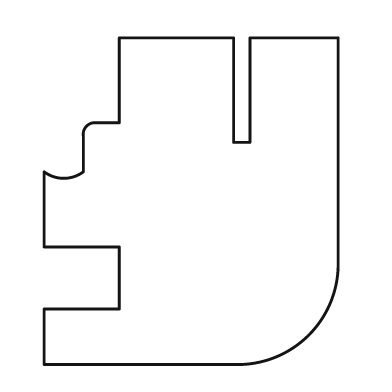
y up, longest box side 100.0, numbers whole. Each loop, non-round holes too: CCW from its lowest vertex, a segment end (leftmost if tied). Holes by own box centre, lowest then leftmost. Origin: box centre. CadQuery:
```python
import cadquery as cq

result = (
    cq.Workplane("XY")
    .moveTo(-45.0, -50.0)
    .lineTo(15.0, -50.0)
    .threePointArc((36.0, -41.0), (45.0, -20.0))
    .lineTo(45.0, 50.0)
    .lineTo(18.0, 50.0)
    .lineTo(18.0, 18.0)
    .lineTo(13.0, 18.0)
    .lineTo(13.0, 50.0)
    .lineTo(-22.0, 50.0)
    .lineTo(-22.0, 24.0)
    .lineTo(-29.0, 24.0)
    .threePointArc((-32.0, 23.0), (-33.0, 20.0))
    .lineTo(-33.0, 9.0)
    .threePointArc((-39.0, 7.0), (-45.0, 9.0))
    .lineTo(-45.0, -14.0)
    .lineTo(-22.0, -14.0)
    .lineTo(-22.0, -33.0)
    .lineTo(-45.0, -33.0)
    .close()
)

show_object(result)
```